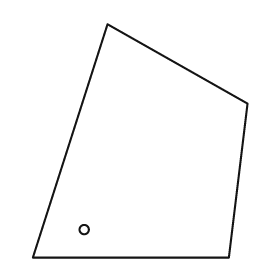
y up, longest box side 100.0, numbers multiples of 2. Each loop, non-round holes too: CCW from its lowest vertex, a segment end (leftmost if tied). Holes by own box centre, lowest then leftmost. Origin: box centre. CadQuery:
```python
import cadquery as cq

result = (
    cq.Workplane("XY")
    .moveTo(-46.0, -50.0)
    .lineTo(38.0, -50.0)
    .lineTo(46.0, 16.0)
    .lineTo(-14.0, 50.0)
    .close()
    .moveTo(-24.0, -38.0)
    .circle(2.0)
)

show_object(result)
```